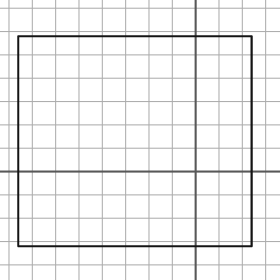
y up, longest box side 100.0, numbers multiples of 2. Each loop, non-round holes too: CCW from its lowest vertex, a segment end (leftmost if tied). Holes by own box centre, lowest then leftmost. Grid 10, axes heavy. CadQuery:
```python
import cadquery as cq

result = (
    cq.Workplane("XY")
    .moveTo(-76.0, -32.0)
    .lineTo(24.0, -32.0)
    .lineTo(24.0, 58.0)
    .lineTo(-76.0, 58.0)
    .close()
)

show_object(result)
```